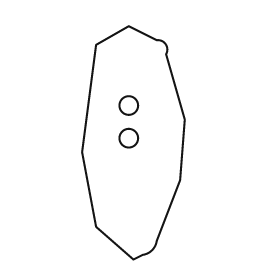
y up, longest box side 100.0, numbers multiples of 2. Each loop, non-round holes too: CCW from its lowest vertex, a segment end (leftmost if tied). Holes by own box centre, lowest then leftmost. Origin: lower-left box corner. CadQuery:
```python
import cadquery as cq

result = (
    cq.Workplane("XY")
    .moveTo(22.0, 0.0)
    .lineTo(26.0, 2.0)
    .threePointArc((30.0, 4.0), (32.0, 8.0))
    .lineTo(42.0, 34.0)
    .lineTo(44.0, 60.0)
    .lineTo(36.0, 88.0)
    .threePointArc((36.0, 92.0), (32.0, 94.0))
    .lineTo(20.0, 100.0)
    .lineTo(6.0, 92.0)
    .lineTo(0.0, 46.0)
    .lineTo(6.0, 14.0)
    .close()
    .moveTo(20.0, 52.0)
    .circle(4.0)
    .moveTo(20.0, 66.0)
    .circle(4.0)
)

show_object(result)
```